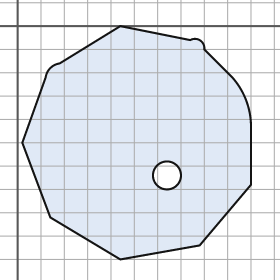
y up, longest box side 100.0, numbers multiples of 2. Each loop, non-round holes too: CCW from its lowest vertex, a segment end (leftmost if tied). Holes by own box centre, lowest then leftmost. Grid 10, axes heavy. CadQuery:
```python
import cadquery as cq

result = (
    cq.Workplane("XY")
    .moveTo(44.0, -100.0)
    .lineTo(78.0, -94.0)
    .lineTo(100.0, -68.0)
    .lineTo(100.0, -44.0)
    .threePointArc((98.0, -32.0), (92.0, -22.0))
    .lineTo(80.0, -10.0)
    .threePointArc((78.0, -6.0), (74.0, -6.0))
    .lineTo(44.0, 0.0)
    .lineTo(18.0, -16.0)
    .threePointArc((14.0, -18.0), (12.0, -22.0))
    .lineTo(2.0, -50.0)
    .lineTo(14.0, -82.0)
    .close()
    .moveTo(64.0, -64.0)
    .circle(6.0)
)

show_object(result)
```